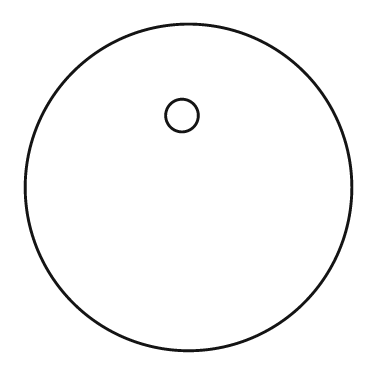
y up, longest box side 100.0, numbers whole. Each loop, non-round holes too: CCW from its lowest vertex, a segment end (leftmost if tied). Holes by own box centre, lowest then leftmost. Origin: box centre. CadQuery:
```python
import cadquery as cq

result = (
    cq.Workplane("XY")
    .moveTo(0.0, 0.0)
    .circle(50.0)
    .moveTo(-2.0, 22.0)
    .circle(5.0)
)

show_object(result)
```